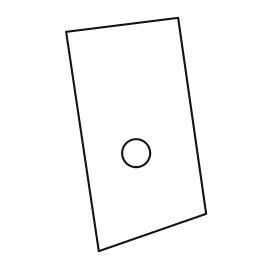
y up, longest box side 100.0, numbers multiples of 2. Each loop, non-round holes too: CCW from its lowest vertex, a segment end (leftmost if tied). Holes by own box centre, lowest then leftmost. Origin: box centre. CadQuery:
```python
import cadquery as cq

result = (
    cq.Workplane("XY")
    .moveTo(-16.0, -50.0)
    .lineTo(30.0, -34.0)
    .lineTo(18.0, 50.0)
    .lineTo(-30.0, 44.0)
    .close()
    .moveTo(0.0, -8.0)
    .circle(6.0)
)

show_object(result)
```